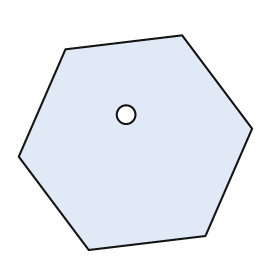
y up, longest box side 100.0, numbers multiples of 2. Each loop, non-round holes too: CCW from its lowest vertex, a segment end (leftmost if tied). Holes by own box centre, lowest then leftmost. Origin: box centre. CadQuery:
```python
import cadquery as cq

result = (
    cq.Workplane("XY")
    .moveTo(-20.0, -46.0)
    .lineTo(30.0, -40.0)
    .lineTo(50.0, 6.0)
    .lineTo(20.0, 46.0)
    .lineTo(-30.0, 40.0)
    .lineTo(-50.0, -6.0)
    .close()
    .moveTo(-4.0, 12.0)
    .circle(4.0)
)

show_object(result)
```